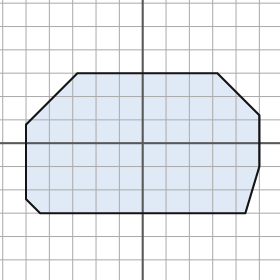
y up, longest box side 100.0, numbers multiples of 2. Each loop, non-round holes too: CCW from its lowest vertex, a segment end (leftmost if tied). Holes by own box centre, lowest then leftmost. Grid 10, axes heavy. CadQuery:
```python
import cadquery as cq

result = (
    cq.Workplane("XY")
    .moveTo(-44.0, -30.0)
    .lineTo(44.0, -30.0)
    .lineTo(50.0, -10.0)
    .lineTo(50.0, 12.0)
    .lineTo(32.0, 30.0)
    .lineTo(-28.0, 30.0)
    .lineTo(-50.0, 8.0)
    .lineTo(-50.0, -24.0)
    .close()
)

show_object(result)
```